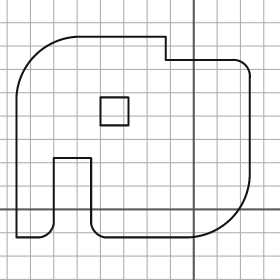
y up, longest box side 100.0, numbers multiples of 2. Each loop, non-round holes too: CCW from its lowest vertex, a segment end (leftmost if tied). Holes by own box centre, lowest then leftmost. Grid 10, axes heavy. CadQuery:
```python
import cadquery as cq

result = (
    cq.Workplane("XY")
    .moveTo(-76.0, -12.0)
    .lineTo(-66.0, -12.0)
    .threePointArc((-62.0, -10.0), (-60.0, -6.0))
    .lineTo(-60.0, 22.0)
    .lineTo(-44.0, 22.0)
    .lineTo(-44.0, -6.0)
    .threePointArc((-42.0, -10.0), (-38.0, -12.0))
    .lineTo(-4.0, -12.0)
    .threePointArc((16.0, -4.0), (24.0, 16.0))
    .lineTo(24.0, 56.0)
    .threePointArc((22.0, 62.0), (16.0, 64.0))
    .lineTo(-12.0, 64.0)
    .lineTo(-12.0, 74.0)
    .lineTo(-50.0, 74.0)
    .threePointArc((-68.0, 66.0), (-76.0, 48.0))
    .close()
    .moveTo(-40.0, 36.0)
    .lineTo(-28.0, 36.0)
    .lineTo(-28.0, 48.0)
    .lineTo(-40.0, 48.0)
    .close()
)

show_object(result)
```